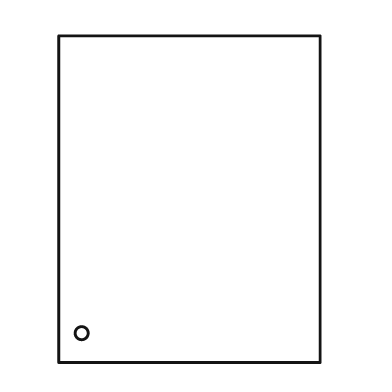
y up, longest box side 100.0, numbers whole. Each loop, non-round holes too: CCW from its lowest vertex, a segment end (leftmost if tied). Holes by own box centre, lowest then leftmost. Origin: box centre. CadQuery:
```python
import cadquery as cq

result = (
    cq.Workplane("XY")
    .moveTo(-40.0, -50.0)
    .lineTo(40.0, -50.0)
    .lineTo(40.0, 50.0)
    .lineTo(-40.0, 50.0)
    .close()
    .moveTo(-33.0, -41.0)
    .circle(2.0)
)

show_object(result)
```